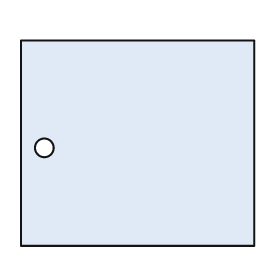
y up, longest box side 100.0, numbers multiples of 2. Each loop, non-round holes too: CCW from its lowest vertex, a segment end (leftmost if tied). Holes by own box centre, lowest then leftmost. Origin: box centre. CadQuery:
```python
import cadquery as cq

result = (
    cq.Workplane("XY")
    .moveTo(-50.0, -44.0)
    .lineTo(50.0, -44.0)
    .lineTo(50.0, 44.0)
    .lineTo(-50.0, 44.0)
    .close()
    .moveTo(-40.0, -2.0)
    .circle(4.0)
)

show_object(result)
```